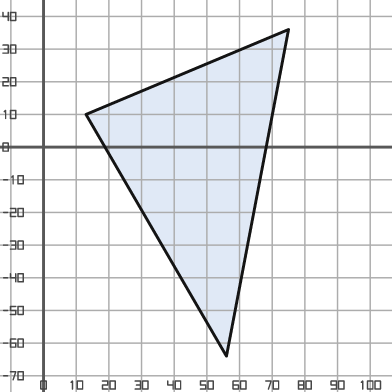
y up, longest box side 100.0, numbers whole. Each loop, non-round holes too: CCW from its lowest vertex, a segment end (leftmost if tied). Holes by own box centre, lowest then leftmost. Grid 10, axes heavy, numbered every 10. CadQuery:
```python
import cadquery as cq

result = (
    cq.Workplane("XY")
    .moveTo(56.0, -64.0)
    .lineTo(75.0, 36.0)
    .lineTo(13.0, 10.0)
    .close()
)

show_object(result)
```